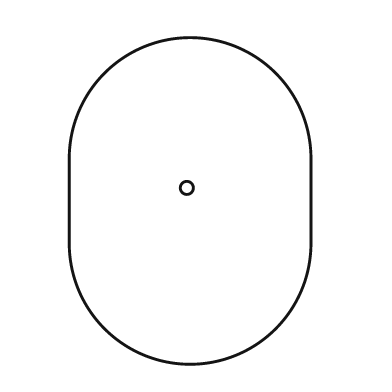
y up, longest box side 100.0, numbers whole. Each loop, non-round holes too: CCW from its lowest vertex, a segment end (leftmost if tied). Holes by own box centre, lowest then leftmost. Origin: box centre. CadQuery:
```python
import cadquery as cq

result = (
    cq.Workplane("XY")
    .moveTo(-37.0, -13.0)
    .threePointArc((0.0, -50.0), (37.0, -13.0))
    .lineTo(37.0, 13.0)
    .threePointArc((0.0, 50.0), (-37.0, 13.0))
    .close()
    .moveTo(-1.0, 4.0)
    .circle(2.0)
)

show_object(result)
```